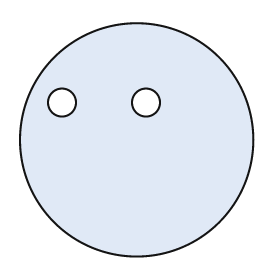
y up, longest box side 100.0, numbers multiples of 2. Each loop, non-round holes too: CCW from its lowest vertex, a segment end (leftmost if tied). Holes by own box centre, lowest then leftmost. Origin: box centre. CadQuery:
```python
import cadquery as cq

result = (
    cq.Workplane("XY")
    .moveTo(0.0, 0.0)
    .circle(50.0)
    .moveTo(-32.0, 16.0)
    .circle(6.0)
    .moveTo(4.0, 16.0)
    .circle(6.0)
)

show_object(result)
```